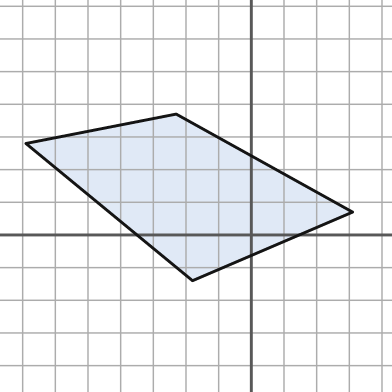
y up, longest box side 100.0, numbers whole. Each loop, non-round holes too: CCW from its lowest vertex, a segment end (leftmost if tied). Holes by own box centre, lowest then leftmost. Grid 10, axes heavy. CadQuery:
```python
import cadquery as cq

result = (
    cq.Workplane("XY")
    .moveTo(-18.0, -14.0)
    .lineTo(31.0, 7.0)
    .lineTo(-23.0, 37.0)
    .lineTo(-69.0, 28.0)
    .close()
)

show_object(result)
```